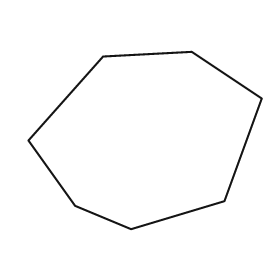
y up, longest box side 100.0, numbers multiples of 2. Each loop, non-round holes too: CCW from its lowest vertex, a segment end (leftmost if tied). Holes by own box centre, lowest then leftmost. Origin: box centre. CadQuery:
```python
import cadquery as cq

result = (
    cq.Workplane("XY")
    .moveTo(-6.0, -38.0)
    .lineTo(34.0, -26.0)
    .lineTo(50.0, 18.0)
    .lineTo(20.0, 38.0)
    .lineTo(-18.0, 36.0)
    .lineTo(-50.0, 0.0)
    .lineTo(-30.0, -28.0)
    .close()
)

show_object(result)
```